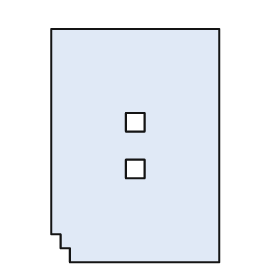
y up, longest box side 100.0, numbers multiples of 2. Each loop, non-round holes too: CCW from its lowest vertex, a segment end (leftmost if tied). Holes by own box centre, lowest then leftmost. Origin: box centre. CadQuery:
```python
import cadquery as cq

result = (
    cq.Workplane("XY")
    .moveTo(-28.0, -50.0)
    .lineTo(36.0, -50.0)
    .lineTo(36.0, 50.0)
    .lineTo(-36.0, 50.0)
    .lineTo(-36.0, -38.0)
    .lineTo(-32.0, -38.0)
    .lineTo(-32.0, -44.0)
    .lineTo(-28.0, -44.0)
    .close()
    .moveTo(-4.0, -14.0)
    .lineTo(4.0, -14.0)
    .lineTo(4.0, -6.0)
    .lineTo(-4.0, -6.0)
    .close()
    .moveTo(-4.0, 6.0)
    .lineTo(4.0, 6.0)
    .lineTo(4.0, 14.0)
    .lineTo(-4.0, 14.0)
    .close()
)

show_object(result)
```